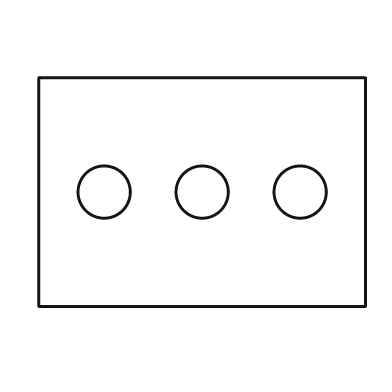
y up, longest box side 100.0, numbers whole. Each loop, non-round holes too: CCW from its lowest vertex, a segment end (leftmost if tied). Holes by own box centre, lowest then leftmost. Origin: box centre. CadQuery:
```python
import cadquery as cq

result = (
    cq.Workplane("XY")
    .moveTo(-50.0, -35.0)
    .lineTo(50.0, -35.0)
    .lineTo(50.0, 35.0)
    .lineTo(-50.0, 35.0)
    .close()
    .moveTo(-30.0, 0.0)
    .circle(8.0)
    .moveTo(0.0, 0.0)
    .circle(8.0)
    .moveTo(30.0, 0.0)
    .circle(8.0)
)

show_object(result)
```